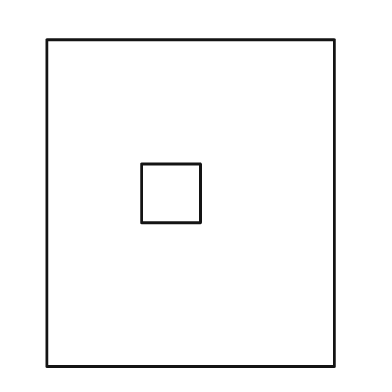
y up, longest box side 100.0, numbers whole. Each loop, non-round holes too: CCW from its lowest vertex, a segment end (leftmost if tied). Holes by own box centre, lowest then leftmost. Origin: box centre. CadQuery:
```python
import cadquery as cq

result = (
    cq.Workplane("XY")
    .moveTo(-44.0, -50.0)
    .lineTo(44.0, -50.0)
    .lineTo(44.0, 50.0)
    .lineTo(-44.0, 50.0)
    .close()
    .moveTo(-15.0, -6.0)
    .lineTo(3.0, -6.0)
    .lineTo(3.0, 12.0)
    .lineTo(-15.0, 12.0)
    .close()
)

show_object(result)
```